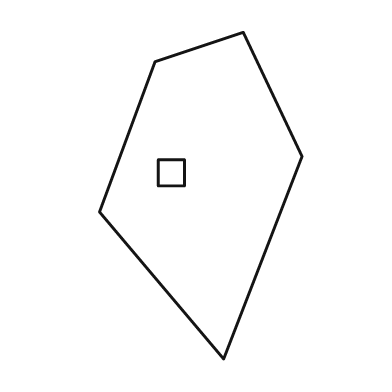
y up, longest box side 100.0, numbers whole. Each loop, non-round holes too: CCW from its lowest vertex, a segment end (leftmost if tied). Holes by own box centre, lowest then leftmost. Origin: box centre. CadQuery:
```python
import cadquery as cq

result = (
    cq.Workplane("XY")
    .moveTo(7.0, -50.0)
    .lineTo(31.0, 12.0)
    .lineTo(13.0, 50.0)
    .lineTo(-14.0, 41.0)
    .lineTo(-31.0, -5.0)
    .close()
    .moveTo(-13.0, 3.0)
    .lineTo(-5.0, 3.0)
    .lineTo(-5.0, 11.0)
    .lineTo(-13.0, 11.0)
    .close()
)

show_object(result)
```